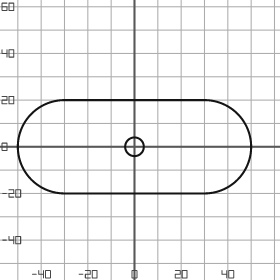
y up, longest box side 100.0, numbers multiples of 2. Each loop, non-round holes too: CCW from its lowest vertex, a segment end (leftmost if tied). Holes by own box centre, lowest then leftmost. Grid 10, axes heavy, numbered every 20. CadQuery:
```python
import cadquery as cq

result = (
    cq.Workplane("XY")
    .moveTo(-30.0, -20.0)
    .lineTo(30.0, -20.0)
    .threePointArc((50.0, 0.0), (30.0, 20.0))
    .lineTo(-30.0, 20.0)
    .threePointArc((-50.0, 0.0), (-30.0, -20.0))
    .close()
    .moveTo(0.0, 0.0)
    .circle(4.0)
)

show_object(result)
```